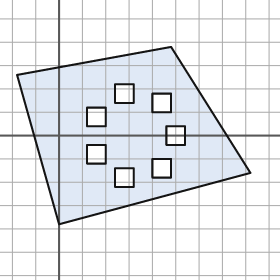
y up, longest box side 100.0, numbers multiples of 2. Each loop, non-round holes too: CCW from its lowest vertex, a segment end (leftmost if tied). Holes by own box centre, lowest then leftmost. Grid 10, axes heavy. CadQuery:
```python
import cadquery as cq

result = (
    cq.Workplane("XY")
    .moveTo(0.0, -38.0)
    .lineTo(82.0, -16.0)
    .lineTo(48.0, 38.0)
    .lineTo(-18.0, 26.0)
    .close()
    .moveTo(24.0, -22.0)
    .lineTo(32.0, -22.0)
    .lineTo(32.0, -14.0)
    .lineTo(24.0, -14.0)
    .close()
    .moveTo(40.0, -18.0)
    .lineTo(48.0, -18.0)
    .lineTo(48.0, -10.0)
    .lineTo(40.0, -10.0)
    .close()
    .moveTo(12.0, -12.0)
    .lineTo(20.0, -12.0)
    .lineTo(20.0, -4.0)
    .lineTo(12.0, -4.0)
    .close()
    .moveTo(46.0, -4.0)
    .lineTo(54.0, -4.0)
    .lineTo(54.0, 4.0)
    .lineTo(46.0, 4.0)
    .close()
    .moveTo(12.0, 4.0)
    .lineTo(20.0, 4.0)
    .lineTo(20.0, 12.0)
    .lineTo(12.0, 12.0)
    .close()
    .moveTo(40.0, 10.0)
    .lineTo(48.0, 10.0)
    .lineTo(48.0, 18.0)
    .lineTo(40.0, 18.0)
    .close()
    .moveTo(24.0, 14.0)
    .lineTo(32.0, 14.0)
    .lineTo(32.0, 22.0)
    .lineTo(24.0, 22.0)
    .close()
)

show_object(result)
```